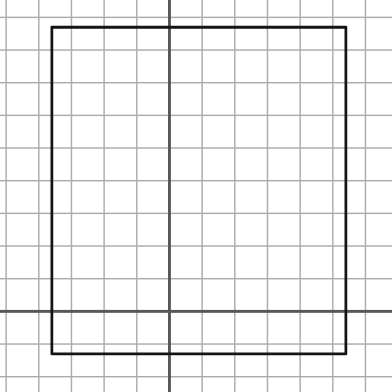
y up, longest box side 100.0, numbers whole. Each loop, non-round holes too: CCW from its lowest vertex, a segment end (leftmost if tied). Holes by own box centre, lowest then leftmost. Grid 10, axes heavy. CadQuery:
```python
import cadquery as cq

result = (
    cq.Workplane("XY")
    .moveTo(-36.0, -13.0)
    .lineTo(54.0, -13.0)
    .lineTo(54.0, 87.0)
    .lineTo(-36.0, 87.0)
    .close()
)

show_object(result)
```